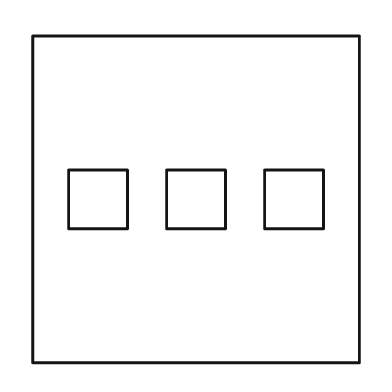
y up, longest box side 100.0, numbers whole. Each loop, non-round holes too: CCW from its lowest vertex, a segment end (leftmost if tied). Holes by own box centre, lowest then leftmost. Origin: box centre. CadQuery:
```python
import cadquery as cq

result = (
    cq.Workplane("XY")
    .moveTo(-50.0, -50.0)
    .lineTo(50.0, -50.0)
    .lineTo(50.0, 50.0)
    .lineTo(-50.0, 50.0)
    .close()
    .moveTo(-39.0, -9.0)
    .lineTo(-21.0, -9.0)
    .lineTo(-21.0, 9.0)
    .lineTo(-39.0, 9.0)
    .close()
    .moveTo(-9.0, -9.0)
    .lineTo(9.0, -9.0)
    .lineTo(9.0, 9.0)
    .lineTo(-9.0, 9.0)
    .close()
    .moveTo(21.0, -9.0)
    .lineTo(39.0, -9.0)
    .lineTo(39.0, 9.0)
    .lineTo(21.0, 9.0)
    .close()
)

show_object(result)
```